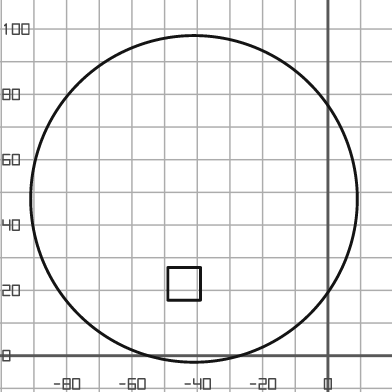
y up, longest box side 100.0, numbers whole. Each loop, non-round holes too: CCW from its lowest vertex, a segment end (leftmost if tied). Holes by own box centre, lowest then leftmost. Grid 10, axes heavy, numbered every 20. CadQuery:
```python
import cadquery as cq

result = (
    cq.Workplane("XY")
    .moveTo(-41.0, 48.0)
    .circle(50.0)
    .moveTo(-49.0, 17.0)
    .lineTo(-39.0, 17.0)
    .lineTo(-39.0, 27.0)
    .lineTo(-49.0, 27.0)
    .close()
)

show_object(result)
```